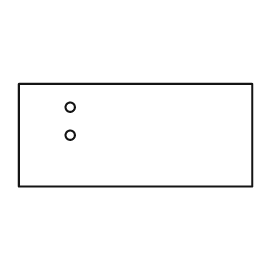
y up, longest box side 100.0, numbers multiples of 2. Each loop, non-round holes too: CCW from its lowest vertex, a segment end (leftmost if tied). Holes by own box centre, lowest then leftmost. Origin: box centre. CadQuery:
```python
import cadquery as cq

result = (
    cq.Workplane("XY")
    .moveTo(-50.0, -22.0)
    .lineTo(50.0, -22.0)
    .lineTo(50.0, 22.0)
    .lineTo(-50.0, 22.0)
    .close()
    .moveTo(-28.0, 0.0)
    .circle(2.0)
    .moveTo(-28.0, 12.0)
    .circle(2.0)
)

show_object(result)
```